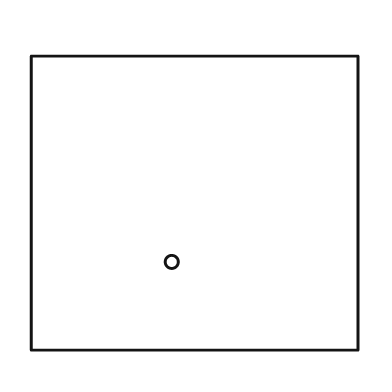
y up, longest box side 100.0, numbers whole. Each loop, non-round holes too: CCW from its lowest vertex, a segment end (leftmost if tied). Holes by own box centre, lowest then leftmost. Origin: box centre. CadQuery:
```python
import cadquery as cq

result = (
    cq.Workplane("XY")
    .moveTo(-50.0, -45.0)
    .lineTo(50.0, -45.0)
    .lineTo(50.0, 45.0)
    .lineTo(-50.0, 45.0)
    .close()
    .moveTo(-7.0, -18.0)
    .circle(2.0)
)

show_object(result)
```